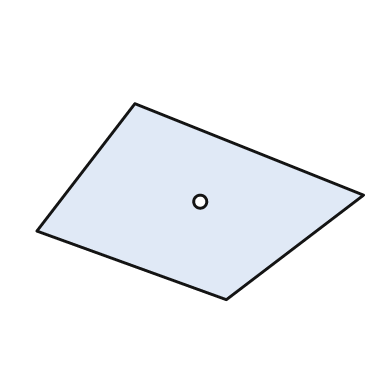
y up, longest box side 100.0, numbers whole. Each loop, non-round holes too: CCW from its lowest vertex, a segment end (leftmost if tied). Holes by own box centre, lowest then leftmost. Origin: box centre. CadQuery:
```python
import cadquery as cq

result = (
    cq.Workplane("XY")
    .moveTo(8.0, -30.0)
    .lineTo(50.0, 2.0)
    .lineTo(-20.0, 30.0)
    .lineTo(-50.0, -9.0)
    .close()
    .moveTo(0.0, 0.0)
    .circle(2.0)
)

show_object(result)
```